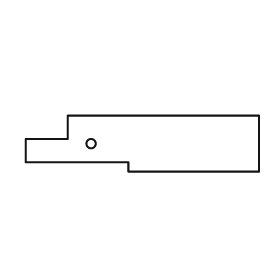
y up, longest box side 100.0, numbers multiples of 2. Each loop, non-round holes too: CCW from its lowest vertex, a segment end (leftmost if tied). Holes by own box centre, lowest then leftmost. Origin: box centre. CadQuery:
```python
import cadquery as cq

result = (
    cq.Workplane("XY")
    .moveTo(-6.0, -12.0)
    .lineTo(50.0, -12.0)
    .lineTo(50.0, 12.0)
    .lineTo(-32.0, 12.0)
    .lineTo(-32.0, 2.0)
    .lineTo(-50.0, 2.0)
    .lineTo(-50.0, -8.0)
    .lineTo(-6.0, -8.0)
    .close()
    .moveTo(-22.0, 0.0)
    .circle(2.0)
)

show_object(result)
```